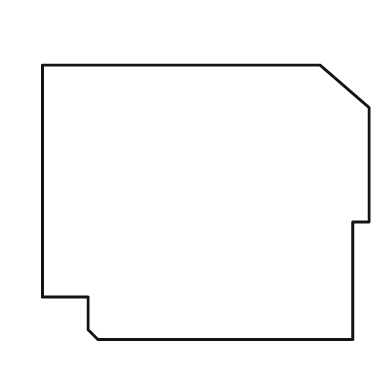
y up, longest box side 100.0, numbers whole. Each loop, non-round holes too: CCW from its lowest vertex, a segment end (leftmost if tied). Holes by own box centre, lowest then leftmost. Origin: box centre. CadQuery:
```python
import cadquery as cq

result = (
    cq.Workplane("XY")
    .moveTo(-33.0, -42.0)
    .lineTo(45.0, -42.0)
    .lineTo(45.0, -6.0)
    .lineTo(50.0, -6.0)
    .lineTo(50.0, 29.0)
    .lineTo(35.0, 42.0)
    .lineTo(-50.0, 42.0)
    .lineTo(-50.0, -29.0)
    .lineTo(-36.0, -29.0)
    .lineTo(-36.0, -39.0)
    .close()
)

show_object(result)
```